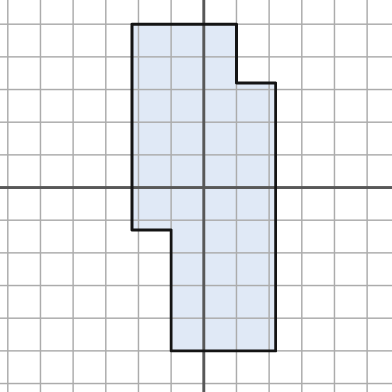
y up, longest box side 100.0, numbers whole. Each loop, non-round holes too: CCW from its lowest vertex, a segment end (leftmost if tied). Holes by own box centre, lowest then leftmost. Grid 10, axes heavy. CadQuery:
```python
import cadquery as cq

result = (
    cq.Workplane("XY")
    .moveTo(-10.0, -50.0)
    .lineTo(22.0, -50.0)
    .lineTo(22.0, 32.0)
    .lineTo(10.0, 32.0)
    .lineTo(10.0, 50.0)
    .lineTo(-22.0, 50.0)
    .lineTo(-22.0, -13.0)
    .lineTo(-10.0, -13.0)
    .close()
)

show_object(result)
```